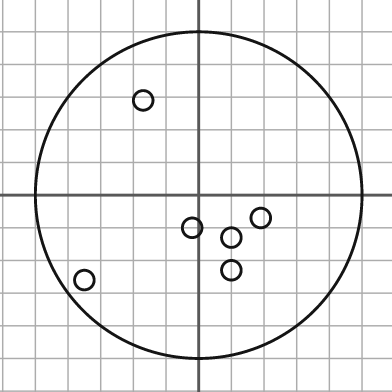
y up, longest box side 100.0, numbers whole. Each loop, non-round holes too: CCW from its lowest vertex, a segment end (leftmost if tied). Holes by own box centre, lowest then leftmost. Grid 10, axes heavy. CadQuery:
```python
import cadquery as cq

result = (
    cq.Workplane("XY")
    .moveTo(0.0, 0.0)
    .circle(50.0)
    .moveTo(-35.0, -26.0)
    .circle(3.0)
    .moveTo(10.0, -23.0)
    .circle(3.0)
    .moveTo(10.0, -13.0)
    .circle(3.0)
    .moveTo(-2.0, -10.0)
    .circle(3.0)
    .moveTo(19.0, -7.0)
    .circle(3.0)
    .moveTo(-17.0, 29.0)
    .circle(3.0)
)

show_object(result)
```